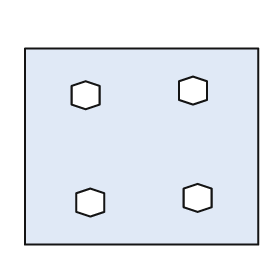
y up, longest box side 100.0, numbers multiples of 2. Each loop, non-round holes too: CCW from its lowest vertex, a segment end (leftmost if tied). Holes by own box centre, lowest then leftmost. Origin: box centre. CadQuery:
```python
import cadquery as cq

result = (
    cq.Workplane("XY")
    .moveTo(-50.0, -42.0)
    .lineTo(50.0, -42.0)
    .lineTo(50.0, 42.0)
    .lineTo(-50.0, 42.0)
    .close()
    .moveTo(-22.0, -30.0)
    .lineTo(-16.0, -28.0)
    .lineTo(-16.0, -20.0)
    .lineTo(-22.0, -18.0)
    .lineTo(-28.0, -20.0)
    .lineTo(-28.0, -28.0)
    .close()
    .moveTo(24.0, -28.0)
    .lineTo(30.0, -26.0)
    .lineTo(30.0, -18.0)
    .lineTo(24.0, -16.0)
    .lineTo(18.0, -18.0)
    .lineTo(18.0, -26.0)
    .close()
    .moveTo(-24.0, 16.0)
    .lineTo(-18.0, 18.0)
    .lineTo(-18.0, 26.0)
    .lineTo(-24.0, 28.0)
    .lineTo(-30.0, 26.0)
    .lineTo(-30.0, 18.0)
    .close()
    .moveTo(22.0, 18.0)
    .lineTo(28.0, 20.0)
    .lineTo(28.0, 28.0)
    .lineTo(22.0, 30.0)
    .lineTo(16.0, 28.0)
    .lineTo(16.0, 20.0)
    .close()
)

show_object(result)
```